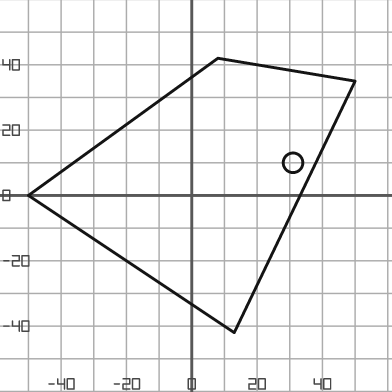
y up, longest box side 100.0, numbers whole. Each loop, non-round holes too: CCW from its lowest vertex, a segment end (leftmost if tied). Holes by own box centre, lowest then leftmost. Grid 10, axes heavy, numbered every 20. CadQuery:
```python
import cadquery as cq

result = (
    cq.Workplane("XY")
    .moveTo(13.0, -42.0)
    .lineTo(50.0, 35.0)
    .lineTo(8.0, 42.0)
    .lineTo(-50.0, 0.0)
    .close()
    .moveTo(31.0, 10.0)
    .circle(3.0)
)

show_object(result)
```